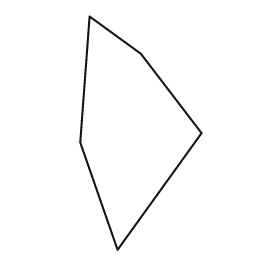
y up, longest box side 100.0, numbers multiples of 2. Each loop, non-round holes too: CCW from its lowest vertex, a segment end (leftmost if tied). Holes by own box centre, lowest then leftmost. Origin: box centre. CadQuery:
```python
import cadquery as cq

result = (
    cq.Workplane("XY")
    .moveTo(-10.0, -50.0)
    .lineTo(26.0, 0.0)
    .lineTo(0.0, 34.0)
    .lineTo(-22.0, 50.0)
    .lineTo(-26.0, -4.0)
    .close()
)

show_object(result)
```